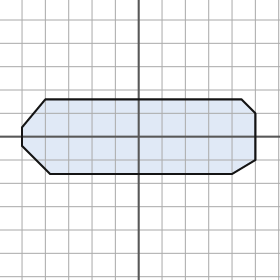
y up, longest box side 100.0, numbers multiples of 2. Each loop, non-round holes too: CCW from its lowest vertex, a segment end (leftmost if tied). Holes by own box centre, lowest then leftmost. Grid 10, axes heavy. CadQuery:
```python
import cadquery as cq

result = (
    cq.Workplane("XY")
    .moveTo(-38.0, -16.0)
    .lineTo(40.0, -16.0)
    .lineTo(50.0, -10.0)
    .lineTo(50.0, 10.0)
    .lineTo(44.0, 16.0)
    .lineTo(-40.0, 16.0)
    .lineTo(-50.0, 4.0)
    .lineTo(-50.0, -4.0)
    .close()
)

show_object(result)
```